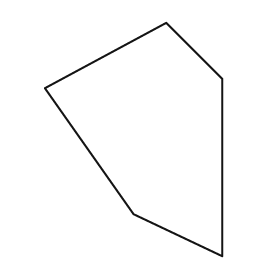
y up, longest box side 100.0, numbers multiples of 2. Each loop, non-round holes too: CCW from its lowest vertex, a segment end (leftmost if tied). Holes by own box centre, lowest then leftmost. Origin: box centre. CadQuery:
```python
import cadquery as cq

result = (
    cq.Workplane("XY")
    .moveTo(38.0, -50.0)
    .lineTo(38.0, 26.0)
    .lineTo(14.0, 50.0)
    .lineTo(-38.0, 22.0)
    .lineTo(0.0, -32.0)
    .close()
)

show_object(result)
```